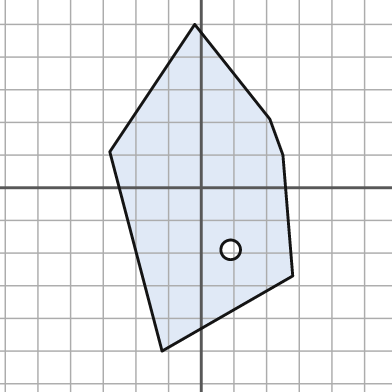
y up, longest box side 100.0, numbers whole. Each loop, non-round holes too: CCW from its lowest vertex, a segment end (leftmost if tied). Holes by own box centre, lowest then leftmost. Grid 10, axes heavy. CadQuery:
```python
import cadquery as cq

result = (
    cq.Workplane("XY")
    .moveTo(-12.0, -50.0)
    .lineTo(28.0, -27.0)
    .lineTo(25.0, 10.0)
    .lineTo(21.0, 21.0)
    .lineTo(-2.0, 50.0)
    .lineTo(-28.0, 11.0)
    .close()
    .moveTo(9.0, -19.0)
    .circle(3.0)
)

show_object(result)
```